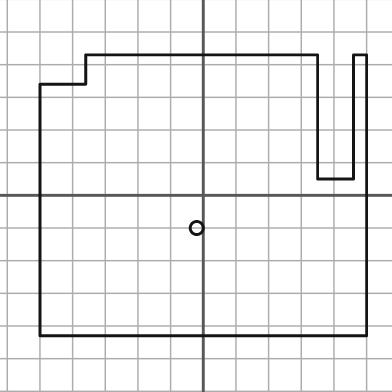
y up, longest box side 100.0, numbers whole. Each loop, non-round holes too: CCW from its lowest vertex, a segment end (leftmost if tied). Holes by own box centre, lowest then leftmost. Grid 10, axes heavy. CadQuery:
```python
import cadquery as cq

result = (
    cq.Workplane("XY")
    .moveTo(-50.0, -43.0)
    .lineTo(50.0, -43.0)
    .lineTo(50.0, 43.0)
    .lineTo(46.0, 43.0)
    .lineTo(46.0, 5.0)
    .lineTo(35.0, 5.0)
    .lineTo(35.0, 43.0)
    .lineTo(-36.0, 43.0)
    .lineTo(-36.0, 34.0)
    .lineTo(-50.0, 34.0)
    .close()
    .moveTo(-2.0, -10.0)
    .circle(2.0)
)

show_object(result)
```